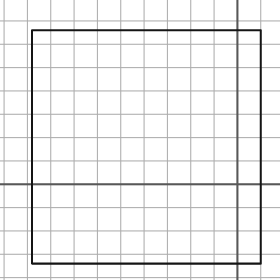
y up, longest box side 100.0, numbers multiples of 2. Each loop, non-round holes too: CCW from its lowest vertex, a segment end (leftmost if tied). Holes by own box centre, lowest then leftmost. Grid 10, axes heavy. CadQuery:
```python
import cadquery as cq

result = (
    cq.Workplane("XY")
    .moveTo(-88.0, -34.0)
    .lineTo(10.0, -34.0)
    .lineTo(10.0, 66.0)
    .lineTo(-88.0, 66.0)
    .close()
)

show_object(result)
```